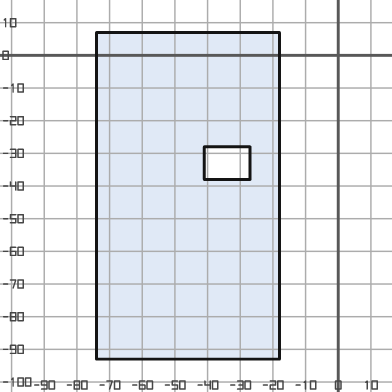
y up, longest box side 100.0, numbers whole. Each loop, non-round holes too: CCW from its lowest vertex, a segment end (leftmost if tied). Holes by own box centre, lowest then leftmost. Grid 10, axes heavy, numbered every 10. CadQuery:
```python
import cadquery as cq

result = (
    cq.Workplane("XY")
    .moveTo(-74.0, -93.0)
    .lineTo(-18.0, -93.0)
    .lineTo(-18.0, 7.0)
    .lineTo(-74.0, 7.0)
    .close()
    .moveTo(-41.0, -38.0)
    .lineTo(-27.0, -38.0)
    .lineTo(-27.0, -28.0)
    .lineTo(-41.0, -28.0)
    .close()
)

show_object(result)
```